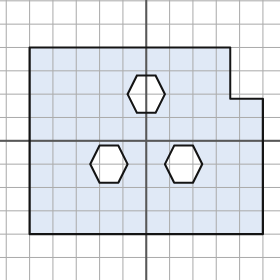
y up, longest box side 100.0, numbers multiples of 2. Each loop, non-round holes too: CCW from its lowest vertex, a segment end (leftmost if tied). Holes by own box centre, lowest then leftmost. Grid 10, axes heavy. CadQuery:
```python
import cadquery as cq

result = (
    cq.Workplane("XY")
    .moveTo(-50.0, -40.0)
    .lineTo(50.0, -40.0)
    .lineTo(50.0, 18.0)
    .lineTo(36.0, 18.0)
    .lineTo(36.0, 40.0)
    .lineTo(-50.0, 40.0)
    .close()
    .moveTo(-20.0, -18.0)
    .lineTo(-12.0, -18.0)
    .lineTo(-8.0, -10.0)
    .lineTo(-12.0, -2.0)
    .lineTo(-20.0, -2.0)
    .lineTo(-24.0, -10.0)
    .close()
    .moveTo(12.0, -18.0)
    .lineTo(20.0, -18.0)
    .lineTo(24.0, -10.0)
    .lineTo(20.0, -2.0)
    .lineTo(12.0, -2.0)
    .lineTo(8.0, -10.0)
    .close()
    .moveTo(-4.0, 12.0)
    .lineTo(4.0, 12.0)
    .lineTo(8.0, 20.0)
    .lineTo(4.0, 28.0)
    .lineTo(-4.0, 28.0)
    .lineTo(-8.0, 20.0)
    .close()
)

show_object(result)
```